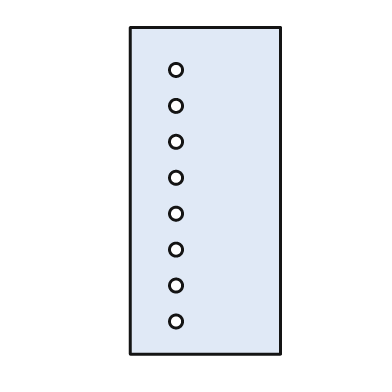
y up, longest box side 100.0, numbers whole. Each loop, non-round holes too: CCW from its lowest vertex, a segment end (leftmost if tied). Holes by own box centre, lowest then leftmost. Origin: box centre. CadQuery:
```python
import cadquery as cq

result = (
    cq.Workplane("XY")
    .moveTo(-23.0, -50.0)
    .lineTo(23.0, -50.0)
    .lineTo(23.0, 50.0)
    .lineTo(-23.0, 50.0)
    .close()
    .moveTo(-9.0, -40.0)
    .circle(2.0)
    .moveTo(-9.0, -29.0)
    .circle(2.0)
    .moveTo(-9.0, -18.0)
    .circle(2.0)
    .moveTo(-9.0, -7.0)
    .circle(2.0)
    .moveTo(-9.0, 4.0)
    .circle(2.0)
    .moveTo(-9.0, 15.0)
    .circle(2.0)
    .moveTo(-9.0, 26.0)
    .circle(2.0)
    .moveTo(-9.0, 37.0)
    .circle(2.0)
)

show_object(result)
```